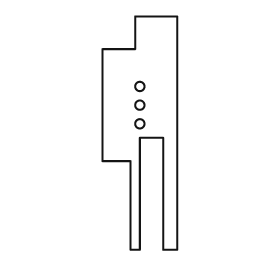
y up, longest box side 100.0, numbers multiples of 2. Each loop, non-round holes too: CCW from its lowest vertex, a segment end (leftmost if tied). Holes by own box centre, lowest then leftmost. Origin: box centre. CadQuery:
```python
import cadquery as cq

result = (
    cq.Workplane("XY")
    .moveTo(-4.0, -50.0)
    .lineTo(0.0, -50.0)
    .lineTo(0.0, -2.0)
    .lineTo(10.0, -2.0)
    .lineTo(10.0, -50.0)
    .lineTo(16.0, -50.0)
    .lineTo(16.0, 50.0)
    .lineTo(-2.0, 50.0)
    .lineTo(-2.0, 36.0)
    .lineTo(-16.0, 36.0)
    .lineTo(-16.0, -12.0)
    .lineTo(-4.0, -12.0)
    .close()
    .moveTo(0.0, 4.0)
    .circle(2.0)
    .moveTo(0.0, 12.0)
    .circle(2.0)
    .moveTo(0.0, 20.0)
    .circle(2.0)
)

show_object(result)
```